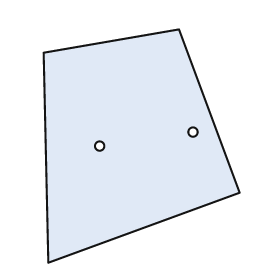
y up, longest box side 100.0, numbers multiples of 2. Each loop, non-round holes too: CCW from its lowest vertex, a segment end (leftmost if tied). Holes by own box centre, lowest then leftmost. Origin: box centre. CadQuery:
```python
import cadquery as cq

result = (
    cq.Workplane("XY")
    .moveTo(-40.0, -50.0)
    .lineTo(42.0, -20.0)
    .lineTo(16.0, 50.0)
    .lineTo(-42.0, 40.0)
    .close()
    .moveTo(-18.0, 0.0)
    .circle(2.0)
    .moveTo(22.0, 6.0)
    .circle(2.0)
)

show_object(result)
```